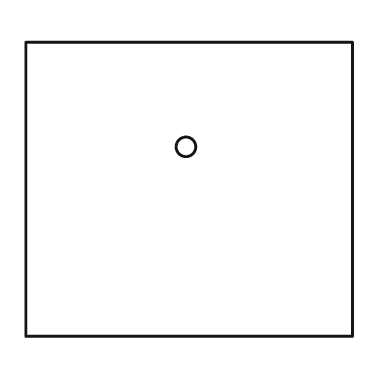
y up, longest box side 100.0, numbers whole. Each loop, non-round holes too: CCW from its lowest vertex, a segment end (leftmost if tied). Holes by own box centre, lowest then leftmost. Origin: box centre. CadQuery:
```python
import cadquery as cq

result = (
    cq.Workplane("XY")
    .moveTo(-50.0, -45.0)
    .lineTo(50.0, -45.0)
    .lineTo(50.0, 45.0)
    .lineTo(-50.0, 45.0)
    .close()
    .moveTo(-1.0, 13.0)
    .circle(3.0)
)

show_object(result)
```